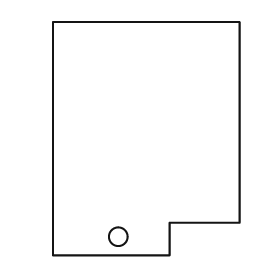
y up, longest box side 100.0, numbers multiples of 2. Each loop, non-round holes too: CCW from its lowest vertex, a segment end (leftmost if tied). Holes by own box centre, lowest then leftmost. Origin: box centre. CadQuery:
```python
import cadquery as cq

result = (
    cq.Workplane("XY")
    .moveTo(-40.0, -50.0)
    .lineTo(10.0, -50.0)
    .lineTo(10.0, -36.0)
    .lineTo(40.0, -36.0)
    .lineTo(40.0, 50.0)
    .lineTo(-40.0, 50.0)
    .close()
    .moveTo(-12.0, -42.0)
    .circle(4.0)
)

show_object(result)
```